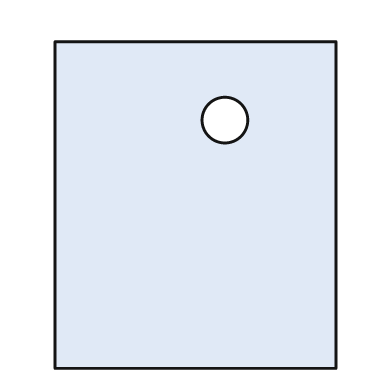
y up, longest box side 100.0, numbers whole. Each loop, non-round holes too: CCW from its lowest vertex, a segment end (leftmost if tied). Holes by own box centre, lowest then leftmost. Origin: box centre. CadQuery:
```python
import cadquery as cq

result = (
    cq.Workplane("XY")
    .moveTo(-43.0, -50.0)
    .lineTo(43.0, -50.0)
    .lineTo(43.0, 50.0)
    .lineTo(-43.0, 50.0)
    .close()
    .moveTo(9.0, 26.0)
    .circle(7.0)
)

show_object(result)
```